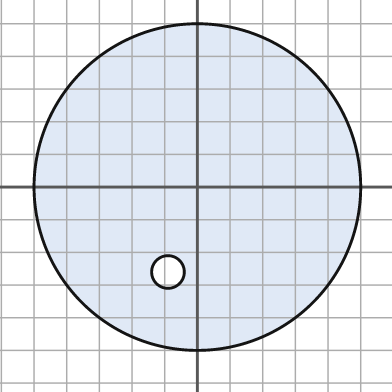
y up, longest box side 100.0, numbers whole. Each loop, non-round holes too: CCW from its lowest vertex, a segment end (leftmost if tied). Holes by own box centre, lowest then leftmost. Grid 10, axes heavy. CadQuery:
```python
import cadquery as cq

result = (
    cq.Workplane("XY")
    .moveTo(0.0, 0.0)
    .circle(50.0)
    .moveTo(-9.0, -26.0)
    .circle(5.0)
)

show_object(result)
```